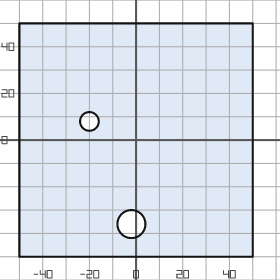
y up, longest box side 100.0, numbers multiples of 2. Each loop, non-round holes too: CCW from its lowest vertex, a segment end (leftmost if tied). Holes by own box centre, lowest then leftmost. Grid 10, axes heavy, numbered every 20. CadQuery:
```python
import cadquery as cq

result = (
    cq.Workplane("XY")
    .moveTo(-50.0, -50.0)
    .lineTo(50.0, -50.0)
    .lineTo(50.0, 50.0)
    .lineTo(-50.0, 50.0)
    .close()
    .moveTo(-2.0, -36.0)
    .circle(6.0)
    .moveTo(-20.0, 8.0)
    .circle(4.0)
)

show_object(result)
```